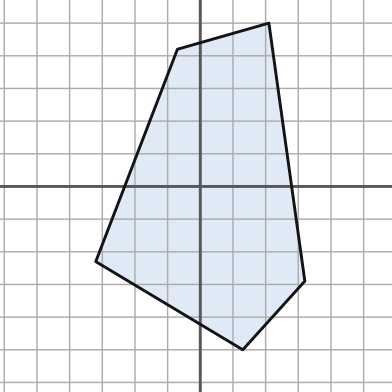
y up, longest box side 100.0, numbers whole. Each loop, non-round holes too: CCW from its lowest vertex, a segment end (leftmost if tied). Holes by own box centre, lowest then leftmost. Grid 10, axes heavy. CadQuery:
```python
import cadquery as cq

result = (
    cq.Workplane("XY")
    .moveTo(13.0, -50.0)
    .lineTo(32.0, -29.0)
    .lineTo(21.0, 50.0)
    .lineTo(-7.0, 42.0)
    .lineTo(-32.0, -23.0)
    .close()
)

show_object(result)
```